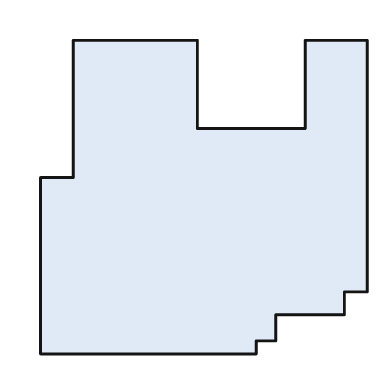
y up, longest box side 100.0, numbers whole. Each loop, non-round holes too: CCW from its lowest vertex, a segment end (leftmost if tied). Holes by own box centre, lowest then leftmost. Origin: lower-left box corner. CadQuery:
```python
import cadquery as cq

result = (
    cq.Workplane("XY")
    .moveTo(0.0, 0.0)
    .lineTo(66.0, 0.0)
    .lineTo(66.0, 4.0)
    .lineTo(72.0, 4.0)
    .lineTo(72.0, 12.0)
    .lineTo(93.0, 12.0)
    .lineTo(93.0, 19.0)
    .lineTo(100.0, 19.0)
    .lineTo(100.0, 96.0)
    .lineTo(81.0, 96.0)
    .lineTo(81.0, 69.0)
    .lineTo(48.0, 69.0)
    .lineTo(48.0, 96.0)
    .lineTo(10.0, 96.0)
    .lineTo(10.0, 54.0)
    .lineTo(0.0, 54.0)
    .close()
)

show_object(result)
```